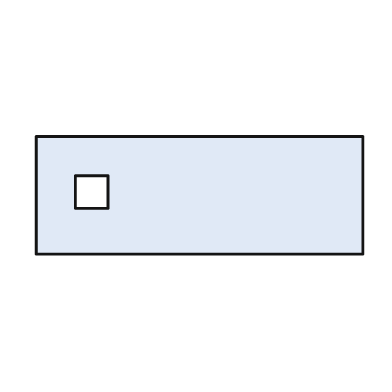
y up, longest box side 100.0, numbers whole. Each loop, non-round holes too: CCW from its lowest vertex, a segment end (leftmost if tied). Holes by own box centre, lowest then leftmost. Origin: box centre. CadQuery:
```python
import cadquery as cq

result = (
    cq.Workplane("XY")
    .moveTo(-50.0, -18.0)
    .lineTo(50.0, -18.0)
    .lineTo(50.0, 18.0)
    .lineTo(-50.0, 18.0)
    .close()
    .moveTo(-38.0, -4.0)
    .lineTo(-28.0, -4.0)
    .lineTo(-28.0, 6.0)
    .lineTo(-38.0, 6.0)
    .close()
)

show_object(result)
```